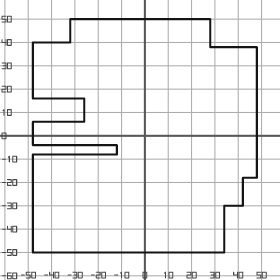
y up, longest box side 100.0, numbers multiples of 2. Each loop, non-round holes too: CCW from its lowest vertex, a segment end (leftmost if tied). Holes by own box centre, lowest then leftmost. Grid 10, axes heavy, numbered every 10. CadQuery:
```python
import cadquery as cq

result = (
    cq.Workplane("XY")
    .moveTo(-48.0, -50.0)
    .lineTo(34.0, -50.0)
    .lineTo(34.0, -30.0)
    .lineTo(42.0, -30.0)
    .lineTo(42.0, -18.0)
    .lineTo(48.0, -18.0)
    .lineTo(48.0, 38.0)
    .lineTo(28.0, 38.0)
    .lineTo(28.0, 50.0)
    .lineTo(-32.0, 50.0)
    .lineTo(-32.0, 40.0)
    .lineTo(-48.0, 40.0)
    .lineTo(-48.0, 16.0)
    .lineTo(-26.0, 16.0)
    .lineTo(-26.0, 6.0)
    .lineTo(-48.0, 6.0)
    .lineTo(-48.0, -4.0)
    .lineTo(-12.0, -4.0)
    .lineTo(-12.0, -8.0)
    .lineTo(-48.0, -8.0)
    .close()
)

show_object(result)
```